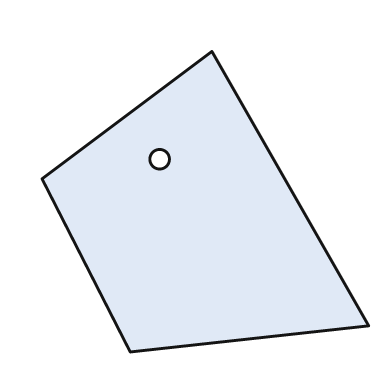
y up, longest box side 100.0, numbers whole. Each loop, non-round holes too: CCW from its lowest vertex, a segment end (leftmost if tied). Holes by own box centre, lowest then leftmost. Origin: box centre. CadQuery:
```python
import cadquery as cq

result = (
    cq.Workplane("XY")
    .moveTo(-23.0, -46.0)
    .lineTo(50.0, -38.0)
    .lineTo(2.0, 46.0)
    .lineTo(-50.0, 7.0)
    .close()
    .moveTo(-14.0, 13.0)
    .circle(3.0)
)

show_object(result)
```